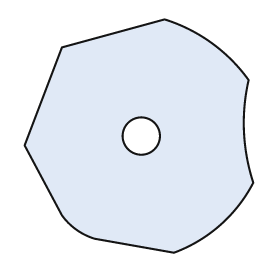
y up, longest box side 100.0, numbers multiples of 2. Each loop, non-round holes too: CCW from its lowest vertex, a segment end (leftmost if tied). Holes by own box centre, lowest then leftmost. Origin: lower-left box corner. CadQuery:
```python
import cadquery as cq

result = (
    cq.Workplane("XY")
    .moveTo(64.0, 0.0)
    .threePointArc((84.0, 12.0), (98.0, 30.0))
    .threePointArc((94.0, 52.0), (96.0, 74.0))
    .threePointArc((80.0, 90.0), (60.0, 100.0))
    .lineTo(16.0, 88.0)
    .lineTo(0.0, 46.0)
    .lineTo(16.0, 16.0)
    .threePointArc((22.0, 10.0), (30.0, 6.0))
    .close()
    .moveTo(50.0, 50.0)
    .circle(8.0)
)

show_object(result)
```